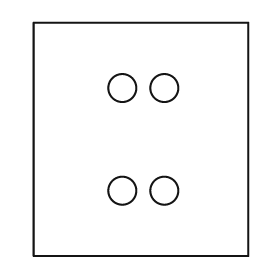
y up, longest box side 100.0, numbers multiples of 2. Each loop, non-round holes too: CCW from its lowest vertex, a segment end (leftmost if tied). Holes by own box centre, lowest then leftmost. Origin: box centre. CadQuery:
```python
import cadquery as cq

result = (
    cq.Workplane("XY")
    .moveTo(-46.0, -50.0)
    .lineTo(46.0, -50.0)
    .lineTo(46.0, 50.0)
    .lineTo(-46.0, 50.0)
    .close()
    .moveTo(-8.0, -22.0)
    .circle(6.0)
    .moveTo(10.0, -22.0)
    .circle(6.0)
    .moveTo(-8.0, 22.0)
    .circle(6.0)
    .moveTo(10.0, 22.0)
    .circle(6.0)
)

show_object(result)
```